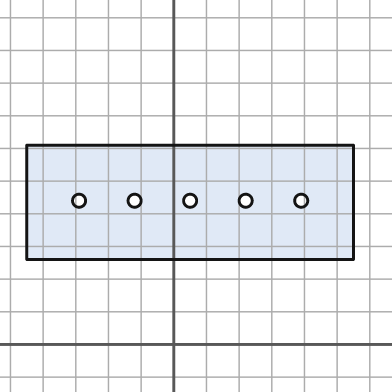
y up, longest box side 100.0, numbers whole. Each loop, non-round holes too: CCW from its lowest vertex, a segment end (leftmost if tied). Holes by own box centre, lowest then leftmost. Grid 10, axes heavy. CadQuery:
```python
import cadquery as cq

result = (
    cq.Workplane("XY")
    .moveTo(-45.0, 26.0)
    .lineTo(55.0, 26.0)
    .lineTo(55.0, 61.0)
    .lineTo(-45.0, 61.0)
    .close()
    .moveTo(-29.0, 44.0)
    .circle(2.0)
    .moveTo(-12.0, 44.0)
    .circle(2.0)
    .moveTo(5.0, 44.0)
    .circle(2.0)
    .moveTo(22.0, 44.0)
    .circle(2.0)
    .moveTo(39.0, 44.0)
    .circle(2.0)
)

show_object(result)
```